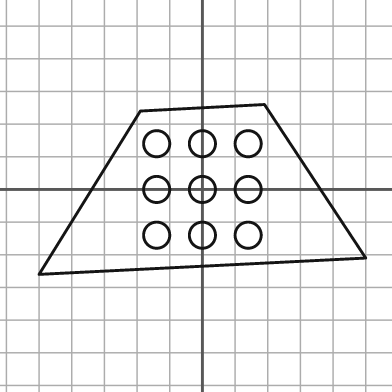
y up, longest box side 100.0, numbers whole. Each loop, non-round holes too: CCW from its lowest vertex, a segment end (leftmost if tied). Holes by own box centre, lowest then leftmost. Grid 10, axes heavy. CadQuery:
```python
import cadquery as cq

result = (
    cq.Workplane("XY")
    .moveTo(-50.0, -26.0)
    .lineTo(50.0, -21.0)
    .lineTo(19.0, 26.0)
    .lineTo(-19.0, 24.0)
    .close()
    .moveTo(-14.0, -14.0)
    .circle(4.0)
    .moveTo(0.0, -14.0)
    .circle(4.0)
    .moveTo(14.0, -14.0)
    .circle(4.0)
    .moveTo(-14.0, 0.0)
    .circle(4.0)
    .moveTo(0.0, 0.0)
    .circle(4.0)
    .moveTo(14.0, 0.0)
    .circle(4.0)
    .moveTo(-14.0, 14.0)
    .circle(4.0)
    .moveTo(0.0, 14.0)
    .circle(4.0)
    .moveTo(14.0, 14.0)
    .circle(4.0)
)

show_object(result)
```